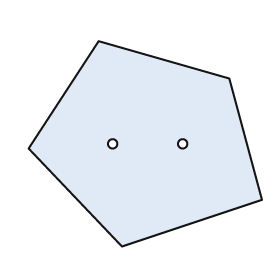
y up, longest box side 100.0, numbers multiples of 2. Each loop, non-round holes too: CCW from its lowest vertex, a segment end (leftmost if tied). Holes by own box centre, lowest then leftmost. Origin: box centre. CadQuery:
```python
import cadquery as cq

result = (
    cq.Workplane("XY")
    .moveTo(-10.0, -44.0)
    .lineTo(50.0, -24.0)
    .lineTo(36.0, 28.0)
    .lineTo(-20.0, 44.0)
    .lineTo(-50.0, -2.0)
    .close()
    .moveTo(-14.0, 0.0)
    .circle(2.0)
    .moveTo(16.0, 0.0)
    .circle(2.0)
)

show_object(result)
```